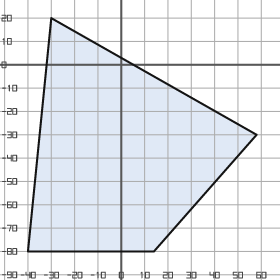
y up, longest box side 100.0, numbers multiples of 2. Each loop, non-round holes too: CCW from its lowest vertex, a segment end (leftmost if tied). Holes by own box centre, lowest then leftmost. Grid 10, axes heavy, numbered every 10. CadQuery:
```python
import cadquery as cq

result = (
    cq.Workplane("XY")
    .moveTo(-40.0, -80.0)
    .lineTo(14.0, -80.0)
    .lineTo(58.0, -30.0)
    .lineTo(-30.0, 20.0)
    .close()
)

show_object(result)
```